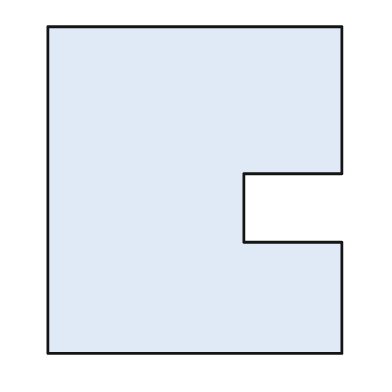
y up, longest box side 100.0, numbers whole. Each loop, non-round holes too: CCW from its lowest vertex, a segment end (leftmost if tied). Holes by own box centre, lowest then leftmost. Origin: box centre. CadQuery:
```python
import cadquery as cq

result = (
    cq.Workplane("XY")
    .moveTo(-45.0, -50.0)
    .lineTo(45.0, -50.0)
    .lineTo(45.0, -16.0)
    .lineTo(15.0, -16.0)
    .lineTo(15.0, 5.0)
    .lineTo(45.0, 5.0)
    .lineTo(45.0, 50.0)
    .lineTo(-45.0, 50.0)
    .close()
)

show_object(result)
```